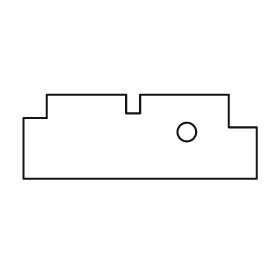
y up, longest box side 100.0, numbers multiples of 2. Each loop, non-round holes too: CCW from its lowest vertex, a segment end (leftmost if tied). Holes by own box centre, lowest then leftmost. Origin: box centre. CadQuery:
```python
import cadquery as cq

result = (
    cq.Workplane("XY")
    .moveTo(-50.0, -18.0)
    .lineTo(50.0, -18.0)
    .lineTo(50.0, 4.0)
    .lineTo(38.0, 4.0)
    .lineTo(38.0, 18.0)
    .lineTo(0.0, 18.0)
    .lineTo(0.0, 10.0)
    .lineTo(-6.0, 10.0)
    .lineTo(-6.0, 18.0)
    .lineTo(-40.0, 18.0)
    .lineTo(-40.0, 8.0)
    .lineTo(-50.0, 8.0)
    .close()
    .moveTo(20.0, 2.0)
    .circle(4.0)
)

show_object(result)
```